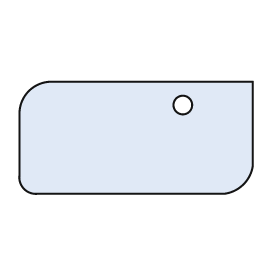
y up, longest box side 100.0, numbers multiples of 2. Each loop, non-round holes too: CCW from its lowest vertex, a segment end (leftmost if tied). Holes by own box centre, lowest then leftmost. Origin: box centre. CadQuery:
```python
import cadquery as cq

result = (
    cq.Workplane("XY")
    .moveTo(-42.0, -24.0)
    .lineTo(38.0, -24.0)
    .threePointArc((46.0, -20.0), (50.0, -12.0))
    .lineTo(50.0, 24.0)
    .lineTo(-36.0, 24.0)
    .threePointArc((-46.0, 20.0), (-50.0, 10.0))
    .lineTo(-50.0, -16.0)
    .threePointArc((-48.0, -22.0), (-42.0, -24.0))
    .close()
    .moveTo(20.0, 14.0)
    .circle(4.0)
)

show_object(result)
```